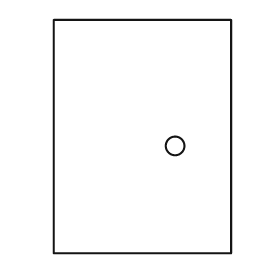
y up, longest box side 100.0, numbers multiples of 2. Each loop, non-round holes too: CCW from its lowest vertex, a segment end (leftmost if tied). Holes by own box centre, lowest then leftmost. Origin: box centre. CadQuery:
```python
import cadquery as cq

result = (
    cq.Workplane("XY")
    .moveTo(-38.0, -50.0)
    .lineTo(38.0, -50.0)
    .lineTo(38.0, 50.0)
    .lineTo(-38.0, 50.0)
    .close()
    .moveTo(14.0, -4.0)
    .circle(4.0)
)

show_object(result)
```